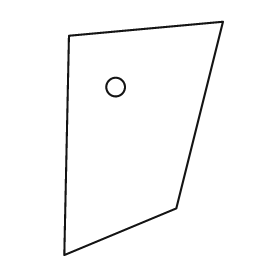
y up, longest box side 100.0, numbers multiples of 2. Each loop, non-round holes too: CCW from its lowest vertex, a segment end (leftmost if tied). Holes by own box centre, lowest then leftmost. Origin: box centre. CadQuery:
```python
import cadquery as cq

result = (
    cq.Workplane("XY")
    .moveTo(-34.0, -50.0)
    .lineTo(14.0, -30.0)
    .lineTo(34.0, 50.0)
    .lineTo(-32.0, 44.0)
    .close()
    .moveTo(-12.0, 22.0)
    .circle(4.0)
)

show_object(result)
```